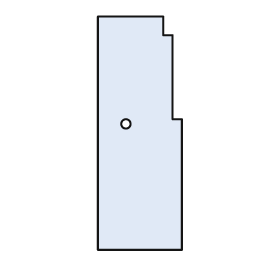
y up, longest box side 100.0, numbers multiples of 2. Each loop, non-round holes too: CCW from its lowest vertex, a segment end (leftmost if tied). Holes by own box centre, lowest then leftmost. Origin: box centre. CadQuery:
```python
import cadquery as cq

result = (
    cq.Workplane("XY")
    .moveTo(-18.0, -50.0)
    .lineTo(18.0, -50.0)
    .lineTo(18.0, 6.0)
    .lineTo(14.0, 6.0)
    .lineTo(14.0, 42.0)
    .lineTo(10.0, 42.0)
    .lineTo(10.0, 50.0)
    .lineTo(-18.0, 50.0)
    .close()
    .moveTo(-6.0, 4.0)
    .circle(2.0)
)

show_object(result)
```